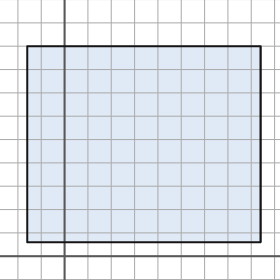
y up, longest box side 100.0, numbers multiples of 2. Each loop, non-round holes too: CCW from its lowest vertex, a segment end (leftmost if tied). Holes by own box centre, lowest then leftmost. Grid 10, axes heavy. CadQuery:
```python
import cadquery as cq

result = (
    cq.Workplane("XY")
    .moveTo(-16.0, 6.0)
    .lineTo(84.0, 6.0)
    .lineTo(84.0, 90.0)
    .lineTo(-16.0, 90.0)
    .close()
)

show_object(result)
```